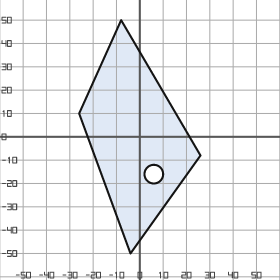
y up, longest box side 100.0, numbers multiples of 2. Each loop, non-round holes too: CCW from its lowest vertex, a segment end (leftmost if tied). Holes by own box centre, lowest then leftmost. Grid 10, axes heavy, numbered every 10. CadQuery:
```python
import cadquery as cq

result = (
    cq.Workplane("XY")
    .moveTo(-4.0, -50.0)
    .lineTo(26.0, -8.0)
    .lineTo(-8.0, 50.0)
    .lineTo(-26.0, 10.0)
    .close()
    .moveTo(6.0, -16.0)
    .circle(4.0)
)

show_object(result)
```